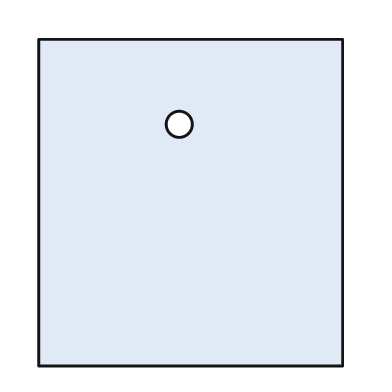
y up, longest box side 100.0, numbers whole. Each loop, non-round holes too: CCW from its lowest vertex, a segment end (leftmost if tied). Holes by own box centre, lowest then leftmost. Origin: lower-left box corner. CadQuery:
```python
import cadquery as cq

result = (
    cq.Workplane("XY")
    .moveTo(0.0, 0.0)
    .lineTo(93.0, 0.0)
    .lineTo(93.0, 100.0)
    .lineTo(0.0, 100.0)
    .close()
    .moveTo(43.0, 74.0)
    .circle(4.0)
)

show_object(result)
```